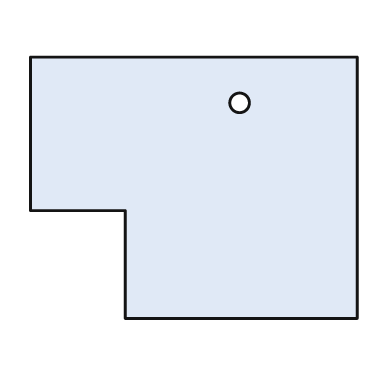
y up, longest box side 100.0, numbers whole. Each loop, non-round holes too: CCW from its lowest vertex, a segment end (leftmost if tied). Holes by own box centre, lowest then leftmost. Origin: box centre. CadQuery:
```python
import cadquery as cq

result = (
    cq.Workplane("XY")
    .moveTo(-21.0, -40.0)
    .lineTo(50.0, -40.0)
    .lineTo(50.0, 40.0)
    .lineTo(-50.0, 40.0)
    .lineTo(-50.0, -7.0)
    .lineTo(-21.0, -7.0)
    .close()
    .moveTo(14.0, 26.0)
    .circle(3.0)
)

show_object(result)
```